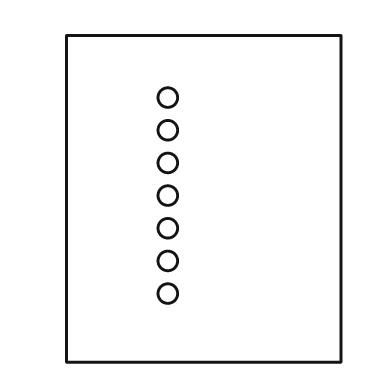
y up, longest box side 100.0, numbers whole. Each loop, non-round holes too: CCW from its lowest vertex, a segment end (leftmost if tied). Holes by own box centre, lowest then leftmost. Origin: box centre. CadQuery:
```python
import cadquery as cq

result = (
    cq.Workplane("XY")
    .moveTo(-42.0, -50.0)
    .lineTo(42.0, -50.0)
    .lineTo(42.0, 50.0)
    .lineTo(-42.0, 50.0)
    .close()
    .moveTo(-11.0, -29.0)
    .circle(3.0)
    .moveTo(-11.0, -19.0)
    .circle(3.0)
    .moveTo(-11.0, -9.0)
    .circle(3.0)
    .moveTo(-11.0, 1.0)
    .circle(3.0)
    .moveTo(-11.0, 11.0)
    .circle(3.0)
    .moveTo(-11.0, 21.0)
    .circle(3.0)
    .moveTo(-11.0, 31.0)
    .circle(3.0)
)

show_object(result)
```